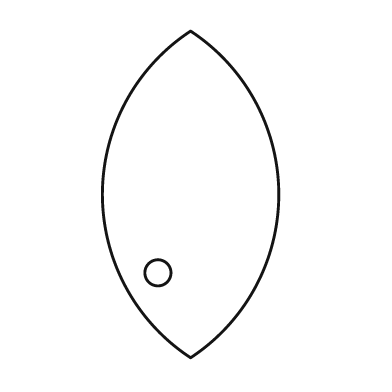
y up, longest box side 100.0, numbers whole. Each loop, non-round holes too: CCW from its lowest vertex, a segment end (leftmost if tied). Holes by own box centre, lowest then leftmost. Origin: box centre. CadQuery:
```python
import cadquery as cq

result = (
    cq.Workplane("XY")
    .moveTo(0.0, -50.0)
    .threePointArc((27.0, 0.0), (0.0, 50.0))
    .threePointArc((-27.0, 0.0), (0.0, -50.0))
    .close()
    .moveTo(-10.0, -24.0)
    .circle(4.0)
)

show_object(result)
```